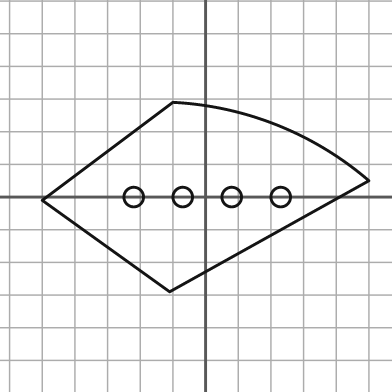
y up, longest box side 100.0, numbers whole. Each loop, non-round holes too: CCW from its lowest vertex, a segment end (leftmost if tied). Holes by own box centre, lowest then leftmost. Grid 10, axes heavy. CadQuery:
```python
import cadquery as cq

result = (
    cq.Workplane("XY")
    .moveTo(-11.0, -29.0)
    .lineTo(50.0, 5.0)
    .threePointArc((22.0, 22.0), (-10.0, 29.0))
    .lineTo(-50.0, -1.0)
    .close()
    .moveTo(-22.0, 0.0)
    .circle(3.0)
    .moveTo(-7.0, 0.0)
    .circle(3.0)
    .moveTo(8.0, 0.0)
    .circle(3.0)
    .moveTo(23.0, 0.0)
    .circle(3.0)
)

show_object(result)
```